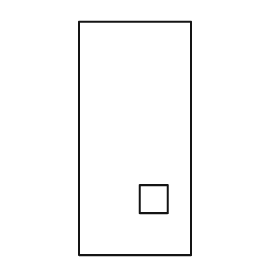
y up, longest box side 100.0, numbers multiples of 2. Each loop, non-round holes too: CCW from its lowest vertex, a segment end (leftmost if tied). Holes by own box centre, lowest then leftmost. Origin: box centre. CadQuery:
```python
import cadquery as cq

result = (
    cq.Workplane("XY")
    .moveTo(-24.0, -50.0)
    .lineTo(24.0, -50.0)
    .lineTo(24.0, 50.0)
    .lineTo(-24.0, 50.0)
    .close()
    .moveTo(2.0, -32.0)
    .lineTo(14.0, -32.0)
    .lineTo(14.0, -20.0)
    .lineTo(2.0, -20.0)
    .close()
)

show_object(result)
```